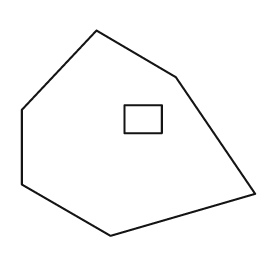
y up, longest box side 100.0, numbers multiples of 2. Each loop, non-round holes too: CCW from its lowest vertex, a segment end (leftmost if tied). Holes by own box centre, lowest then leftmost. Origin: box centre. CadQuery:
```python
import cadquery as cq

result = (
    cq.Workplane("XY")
    .moveTo(-12.0, -44.0)
    .lineTo(50.0, -26.0)
    .lineTo(16.0, 24.0)
    .lineTo(-18.0, 44.0)
    .lineTo(-50.0, 10.0)
    .lineTo(-50.0, -22.0)
    .close()
    .moveTo(-6.0, 0.0)
    .lineTo(10.0, 0.0)
    .lineTo(10.0, 12.0)
    .lineTo(-6.0, 12.0)
    .close()
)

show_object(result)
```